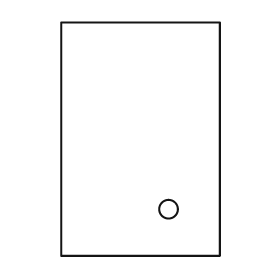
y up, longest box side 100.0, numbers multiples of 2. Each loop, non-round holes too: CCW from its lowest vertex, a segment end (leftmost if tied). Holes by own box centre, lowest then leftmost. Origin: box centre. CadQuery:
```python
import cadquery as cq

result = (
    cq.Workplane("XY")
    .moveTo(-34.0, -50.0)
    .lineTo(34.0, -50.0)
    .lineTo(34.0, 50.0)
    .lineTo(-34.0, 50.0)
    .close()
    .moveTo(12.0, -30.0)
    .circle(4.0)
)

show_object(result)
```